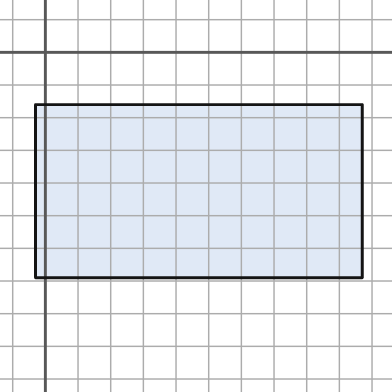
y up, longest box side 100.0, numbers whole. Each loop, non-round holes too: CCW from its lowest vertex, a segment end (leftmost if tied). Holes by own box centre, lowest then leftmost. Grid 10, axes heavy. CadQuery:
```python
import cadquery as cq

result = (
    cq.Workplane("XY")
    .moveTo(-3.0, -69.0)
    .lineTo(97.0, -69.0)
    .lineTo(97.0, -16.0)
    .lineTo(-3.0, -16.0)
    .close()
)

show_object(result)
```